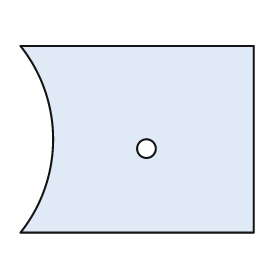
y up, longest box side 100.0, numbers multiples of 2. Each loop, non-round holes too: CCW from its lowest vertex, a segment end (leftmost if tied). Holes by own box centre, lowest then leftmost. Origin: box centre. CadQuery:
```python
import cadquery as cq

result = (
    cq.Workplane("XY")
    .moveTo(-50.0, -40.0)
    .lineTo(50.0, -40.0)
    .lineTo(50.0, 40.0)
    .lineTo(-50.0, 40.0)
    .threePointArc((-36.0, 0.0), (-50.0, -40.0))
    .close()
    .moveTo(4.0, -4.0)
    .circle(4.0)
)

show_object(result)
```